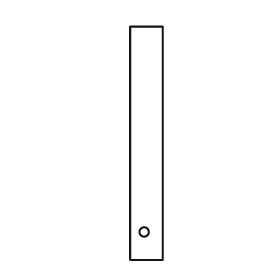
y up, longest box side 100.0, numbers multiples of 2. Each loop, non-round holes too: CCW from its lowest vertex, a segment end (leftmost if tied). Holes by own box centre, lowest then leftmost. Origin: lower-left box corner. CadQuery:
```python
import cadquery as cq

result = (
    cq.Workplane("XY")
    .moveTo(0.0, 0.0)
    .lineTo(14.0, 0.0)
    .lineTo(14.0, 100.0)
    .lineTo(0.0, 100.0)
    .close()
    .moveTo(6.0, 12.0)
    .circle(2.0)
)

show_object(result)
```